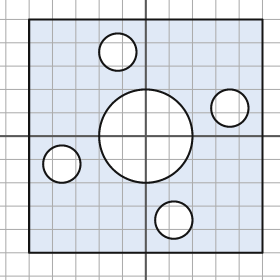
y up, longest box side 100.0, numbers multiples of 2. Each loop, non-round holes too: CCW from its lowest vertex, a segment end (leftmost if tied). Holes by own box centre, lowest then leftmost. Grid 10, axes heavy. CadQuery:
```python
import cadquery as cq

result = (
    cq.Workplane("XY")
    .moveTo(-50.0, -50.0)
    .lineTo(50.0, -50.0)
    .lineTo(50.0, 50.0)
    .lineTo(-50.0, 50.0)
    .close()
    .moveTo(12.0, -36.0)
    .circle(8.0)
    .moveTo(-36.0, -12.0)
    .circle(8.0)
    .moveTo(0.0, 0.0)
    .circle(20.0)
    .moveTo(36.0, 12.0)
    .circle(8.0)
    .moveTo(-12.0, 36.0)
    .circle(8.0)
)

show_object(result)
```